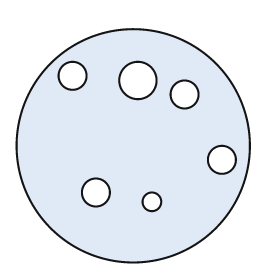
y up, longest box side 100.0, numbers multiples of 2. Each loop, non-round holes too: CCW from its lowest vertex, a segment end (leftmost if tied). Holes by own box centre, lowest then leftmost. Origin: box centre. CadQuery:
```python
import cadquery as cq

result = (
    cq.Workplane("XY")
    .moveTo(0.0, 0.0)
    .circle(50.0)
    .moveTo(8.0, -24.0)
    .circle(4.0)
    .moveTo(-16.0, -20.0)
    .circle(6.0)
    .moveTo(38.0, -6.0)
    .circle(6.0)
    .moveTo(22.0, 22.0)
    .circle(6.0)
    .moveTo(2.0, 28.0)
    .circle(8.0)
    .moveTo(-26.0, 30.0)
    .circle(6.0)
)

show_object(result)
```